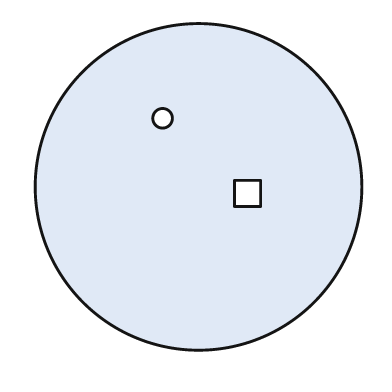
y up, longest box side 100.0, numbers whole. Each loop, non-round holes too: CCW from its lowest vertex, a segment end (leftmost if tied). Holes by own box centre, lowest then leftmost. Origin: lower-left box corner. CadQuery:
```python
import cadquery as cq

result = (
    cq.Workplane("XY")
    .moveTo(50.0, 50.0)
    .circle(50.0)
    .moveTo(61.0, 44.0)
    .lineTo(69.0, 44.0)
    .lineTo(69.0, 52.0)
    .lineTo(61.0, 52.0)
    .close()
    .moveTo(39.0, 71.0)
    .circle(3.0)
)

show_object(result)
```